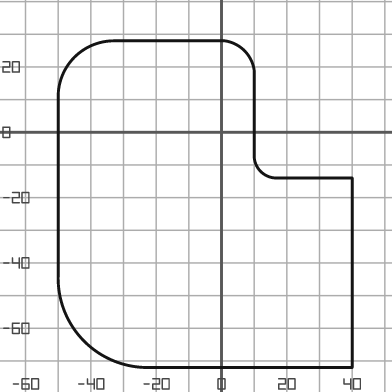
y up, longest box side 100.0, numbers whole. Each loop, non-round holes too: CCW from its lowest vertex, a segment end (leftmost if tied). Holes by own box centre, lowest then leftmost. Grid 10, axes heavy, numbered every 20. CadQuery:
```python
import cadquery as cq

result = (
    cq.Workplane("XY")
    .moveTo(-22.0, -72.0)
    .lineTo(40.0, -72.0)
    .lineTo(40.0, -14.0)
    .lineTo(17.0, -14.0)
    .threePointArc((12.0, -12.0), (10.0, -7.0))
    .lineTo(10.0, 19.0)
    .threePointArc((7.0, 25.0), (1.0, 28.0))
    .lineTo(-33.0, 28.0)
    .threePointArc((-45.0, 23.0), (-50.0, 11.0))
    .lineTo(-50.0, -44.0)
    .threePointArc((-42.0, -64.0), (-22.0, -72.0))
    .close()
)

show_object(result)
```